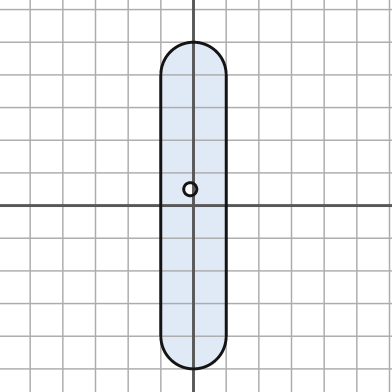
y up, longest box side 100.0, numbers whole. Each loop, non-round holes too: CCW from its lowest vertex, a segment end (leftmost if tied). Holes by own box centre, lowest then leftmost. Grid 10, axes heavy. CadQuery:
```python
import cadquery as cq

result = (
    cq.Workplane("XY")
    .moveTo(-10.0, -40.0)
    .threePointArc((0.0, -50.0), (10.0, -40.0))
    .lineTo(10.0, 40.0)
    .threePointArc((0.0, 50.0), (-10.0, 40.0))
    .close()
    .moveTo(-1.0, 5.0)
    .circle(2.0)
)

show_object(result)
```